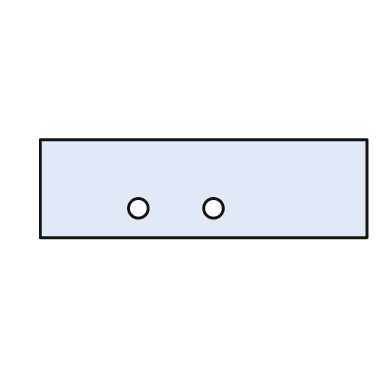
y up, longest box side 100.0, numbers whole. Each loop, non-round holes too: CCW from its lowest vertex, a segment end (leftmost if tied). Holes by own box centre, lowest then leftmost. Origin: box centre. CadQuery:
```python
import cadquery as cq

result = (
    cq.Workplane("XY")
    .moveTo(-50.0, -15.0)
    .lineTo(50.0, -15.0)
    .lineTo(50.0, 15.0)
    .lineTo(-50.0, 15.0)
    .close()
    .moveTo(-20.0, -6.0)
    .circle(3.0)
    .moveTo(3.0, -6.0)
    .circle(3.0)
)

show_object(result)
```